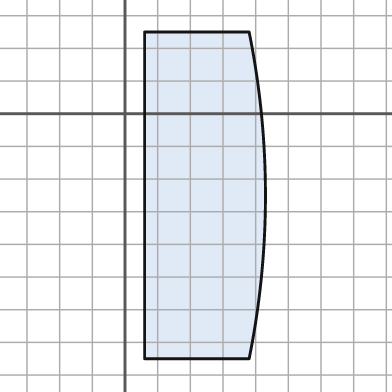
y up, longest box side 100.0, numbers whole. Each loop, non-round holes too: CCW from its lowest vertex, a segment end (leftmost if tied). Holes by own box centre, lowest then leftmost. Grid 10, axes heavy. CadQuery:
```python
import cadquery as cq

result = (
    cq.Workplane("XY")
    .moveTo(6.0, -75.0)
    .lineTo(38.0, -75.0)
    .threePointArc((43.0, -25.0), (38.0, 25.0))
    .lineTo(6.0, 25.0)
    .close()
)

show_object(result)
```